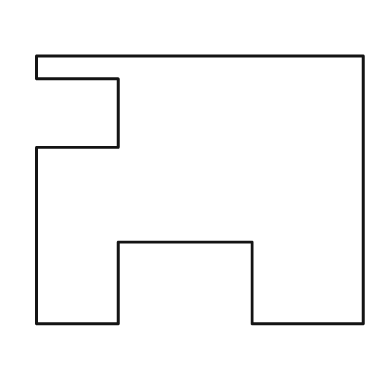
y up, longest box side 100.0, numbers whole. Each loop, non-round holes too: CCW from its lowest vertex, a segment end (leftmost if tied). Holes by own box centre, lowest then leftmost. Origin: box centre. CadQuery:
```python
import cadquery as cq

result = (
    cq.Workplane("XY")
    .moveTo(-50.0, -41.0)
    .lineTo(-25.0, -41.0)
    .lineTo(-25.0, -16.0)
    .lineTo(16.0, -16.0)
    .lineTo(16.0, -41.0)
    .lineTo(50.0, -41.0)
    .lineTo(50.0, 41.0)
    .lineTo(-50.0, 41.0)
    .lineTo(-50.0, 34.0)
    .lineTo(-25.0, 34.0)
    .lineTo(-25.0, 13.0)
    .lineTo(-50.0, 13.0)
    .close()
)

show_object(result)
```